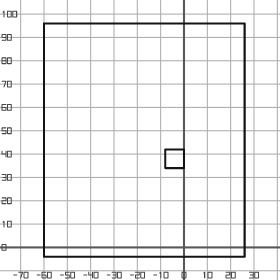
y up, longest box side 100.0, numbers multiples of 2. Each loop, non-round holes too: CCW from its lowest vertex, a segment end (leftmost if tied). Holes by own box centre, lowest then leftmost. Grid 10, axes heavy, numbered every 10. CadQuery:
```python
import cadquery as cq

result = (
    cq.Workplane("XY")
    .moveTo(-60.0, -4.0)
    .lineTo(26.0, -4.0)
    .lineTo(26.0, 96.0)
    .lineTo(-60.0, 96.0)
    .close()
    .moveTo(-8.0, 34.0)
    .lineTo(0.0, 34.0)
    .lineTo(0.0, 42.0)
    .lineTo(-8.0, 42.0)
    .close()
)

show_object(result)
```